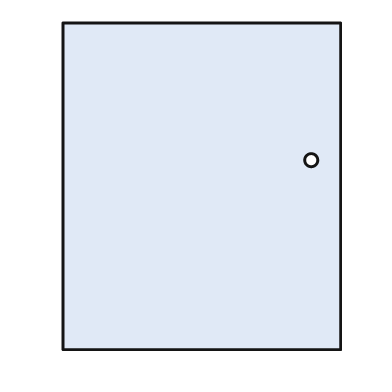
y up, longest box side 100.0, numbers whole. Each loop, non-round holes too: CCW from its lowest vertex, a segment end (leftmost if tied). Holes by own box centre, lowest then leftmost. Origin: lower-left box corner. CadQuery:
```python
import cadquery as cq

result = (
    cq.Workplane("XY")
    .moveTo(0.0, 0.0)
    .lineTo(85.0, 0.0)
    .lineTo(85.0, 100.0)
    .lineTo(0.0, 100.0)
    .close()
    .moveTo(76.0, 58.0)
    .circle(2.0)
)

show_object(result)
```